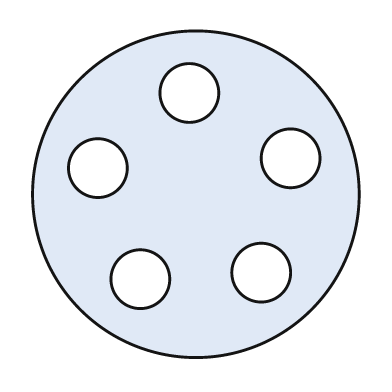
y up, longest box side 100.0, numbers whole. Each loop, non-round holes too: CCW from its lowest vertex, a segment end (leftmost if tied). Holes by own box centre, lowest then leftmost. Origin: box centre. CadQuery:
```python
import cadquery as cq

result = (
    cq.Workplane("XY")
    .moveTo(0.0, 0.0)
    .circle(50.0)
    .moveTo(-17.0, -26.0)
    .circle(9.0)
    .moveTo(20.0, -24.0)
    .circle(9.0)
    .moveTo(-30.0, 8.0)
    .circle(9.0)
    .moveTo(29.0, 11.0)
    .circle(9.0)
    .moveTo(-2.0, 31.0)
    .circle(9.0)
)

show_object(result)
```